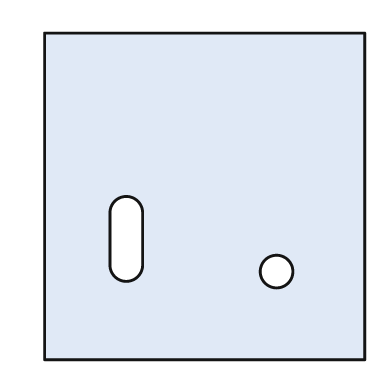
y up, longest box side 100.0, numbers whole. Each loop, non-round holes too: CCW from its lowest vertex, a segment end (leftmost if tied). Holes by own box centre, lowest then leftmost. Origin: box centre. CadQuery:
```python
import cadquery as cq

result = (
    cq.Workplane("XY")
    .moveTo(-49.0, -50.0)
    .lineTo(49.0, -50.0)
    .lineTo(49.0, 50.0)
    .lineTo(-49.0, 50.0)
    .close()
    .moveTo(22.0, -23.0)
    .circle(5.0)
    .moveTo(-29.0, -21.0)
    .threePointArc((-24.0, -26.0), (-19.0, -21.0))
    .lineTo(-19.0, -5.0)
    .threePointArc((-24.0, 0.0), (-29.0, -5.0))
    .close()
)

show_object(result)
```